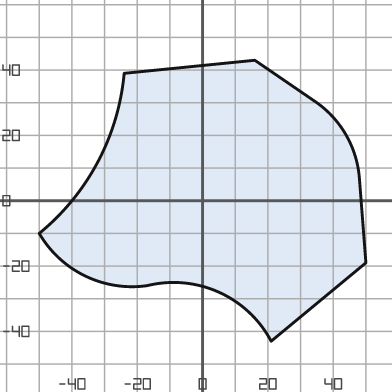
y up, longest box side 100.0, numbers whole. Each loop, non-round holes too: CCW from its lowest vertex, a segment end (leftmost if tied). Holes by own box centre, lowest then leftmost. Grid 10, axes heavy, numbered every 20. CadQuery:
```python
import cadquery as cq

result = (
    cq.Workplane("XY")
    .moveTo(21.0, -43.0)
    .lineTo(50.0, -19.0)
    .lineTo(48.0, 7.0)
    .threePointArc((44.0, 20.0), (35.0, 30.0))
    .lineTo(16.0, 43.0)
    .lineTo(-24.0, 39.0)
    .threePointArc((-32.0, 12.0), (-50.0, -10.0))
    .threePointArc((-36.0, -23.0), (-17.0, -26.0))
    .threePointArc((5.0, -28.0), (21.0, -43.0))
    .close()
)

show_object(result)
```